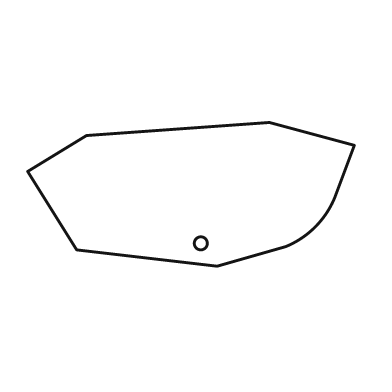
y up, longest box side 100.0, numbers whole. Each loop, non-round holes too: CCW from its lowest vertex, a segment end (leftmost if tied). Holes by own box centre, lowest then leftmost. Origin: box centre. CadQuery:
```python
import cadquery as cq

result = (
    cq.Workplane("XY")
    .moveTo(8.0, -22.0)
    .lineTo(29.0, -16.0)
    .threePointArc((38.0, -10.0), (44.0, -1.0))
    .lineTo(50.0, 15.0)
    .lineTo(24.0, 22.0)
    .lineTo(-32.0, 18.0)
    .lineTo(-50.0, 7.0)
    .lineTo(-35.0, -17.0)
    .close()
    .moveTo(3.0, -15.0)
    .circle(2.0)
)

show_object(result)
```